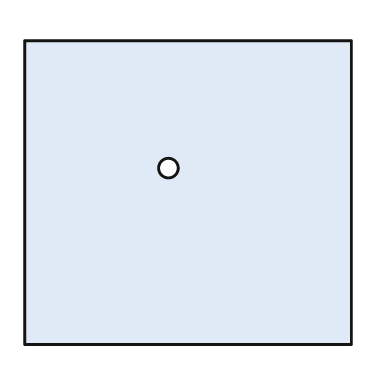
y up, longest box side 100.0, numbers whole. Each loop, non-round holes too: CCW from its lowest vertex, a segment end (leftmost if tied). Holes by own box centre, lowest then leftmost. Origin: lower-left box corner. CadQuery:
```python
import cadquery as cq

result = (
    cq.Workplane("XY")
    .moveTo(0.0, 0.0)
    .lineTo(100.0, 0.0)
    .lineTo(100.0, 93.0)
    .lineTo(0.0, 93.0)
    .close()
    .moveTo(44.0, 54.0)
    .circle(3.0)
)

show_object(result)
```